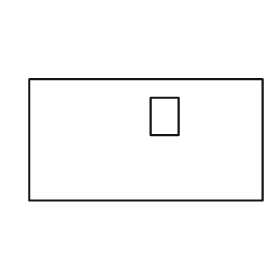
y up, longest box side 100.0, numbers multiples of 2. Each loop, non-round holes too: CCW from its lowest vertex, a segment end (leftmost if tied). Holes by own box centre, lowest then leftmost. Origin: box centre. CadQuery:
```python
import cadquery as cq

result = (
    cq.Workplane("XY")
    .moveTo(-50.0, -26.0)
    .lineTo(50.0, -26.0)
    .lineTo(50.0, 26.0)
    .lineTo(-50.0, 26.0)
    .close()
    .moveTo(2.0, 2.0)
    .lineTo(14.0, 2.0)
    .lineTo(14.0, 18.0)
    .lineTo(2.0, 18.0)
    .close()
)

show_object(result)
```